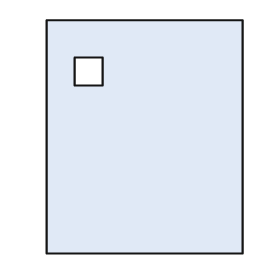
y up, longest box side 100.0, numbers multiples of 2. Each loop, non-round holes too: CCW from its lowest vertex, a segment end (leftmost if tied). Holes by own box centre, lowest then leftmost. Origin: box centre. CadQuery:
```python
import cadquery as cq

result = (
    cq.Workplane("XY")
    .moveTo(-42.0, -50.0)
    .lineTo(42.0, -50.0)
    .lineTo(42.0, 50.0)
    .lineTo(-42.0, 50.0)
    .close()
    .moveTo(-30.0, 22.0)
    .lineTo(-18.0, 22.0)
    .lineTo(-18.0, 34.0)
    .lineTo(-30.0, 34.0)
    .close()
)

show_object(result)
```